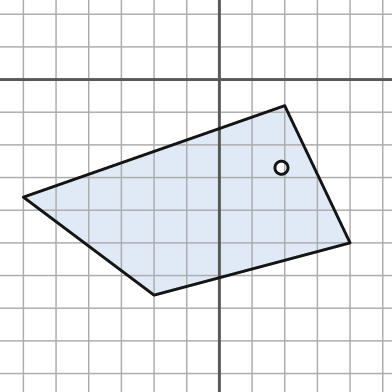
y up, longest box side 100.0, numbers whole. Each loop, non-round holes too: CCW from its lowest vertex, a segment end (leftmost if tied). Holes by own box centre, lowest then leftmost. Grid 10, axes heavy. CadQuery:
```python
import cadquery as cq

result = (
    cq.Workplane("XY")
    .moveTo(-20.0, -66.0)
    .lineTo(40.0, -50.0)
    .lineTo(20.0, -8.0)
    .lineTo(-60.0, -36.0)
    .close()
    .moveTo(19.0, -27.0)
    .circle(2.0)
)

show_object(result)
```